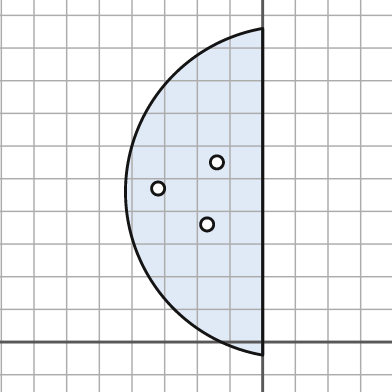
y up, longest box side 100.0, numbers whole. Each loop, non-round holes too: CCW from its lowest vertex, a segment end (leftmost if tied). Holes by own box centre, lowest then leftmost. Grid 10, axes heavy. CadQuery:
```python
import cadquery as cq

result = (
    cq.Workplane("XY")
    .moveTo(0.0, -4.0)
    .lineTo(0.0, 96.0)
    .threePointArc((-42.0, 46.0), (0.0, -4.0))
    .close()
    .moveTo(-17.0, 36.0)
    .circle(2.0)
    .moveTo(-32.0, 47.0)
    .circle(2.0)
    .moveTo(-14.0, 55.0)
    .circle(2.0)
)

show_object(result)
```